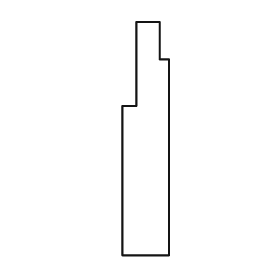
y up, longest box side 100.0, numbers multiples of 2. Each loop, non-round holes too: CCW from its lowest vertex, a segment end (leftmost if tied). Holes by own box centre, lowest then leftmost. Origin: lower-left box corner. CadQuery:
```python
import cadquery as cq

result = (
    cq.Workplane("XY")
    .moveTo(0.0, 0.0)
    .lineTo(20.0, 0.0)
    .lineTo(20.0, 84.0)
    .lineTo(16.0, 84.0)
    .lineTo(16.0, 100.0)
    .lineTo(6.0, 100.0)
    .lineTo(6.0, 64.0)
    .lineTo(0.0, 64.0)
    .close()
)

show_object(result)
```